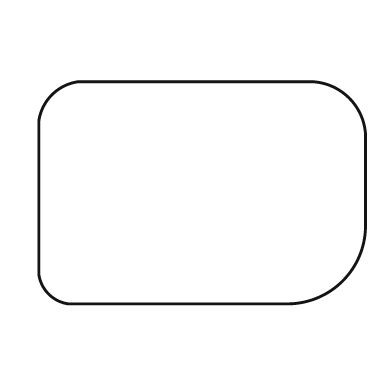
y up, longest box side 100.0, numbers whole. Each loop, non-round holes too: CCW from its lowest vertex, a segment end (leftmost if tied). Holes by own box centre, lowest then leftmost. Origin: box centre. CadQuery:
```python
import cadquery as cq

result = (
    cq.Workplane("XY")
    .moveTo(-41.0, -34.0)
    .lineTo(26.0, -34.0)
    .threePointArc((43.0, -27.0), (50.0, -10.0))
    .lineTo(50.0, 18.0)
    .threePointArc((45.0, 29.0), (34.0, 34.0))
    .lineTo(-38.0, 34.0)
    .threePointArc((-46.0, 30.0), (-50.0, 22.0))
    .lineTo(-50.0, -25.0)
    .threePointArc((-47.0, -31.0), (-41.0, -34.0))
    .close()
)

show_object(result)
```